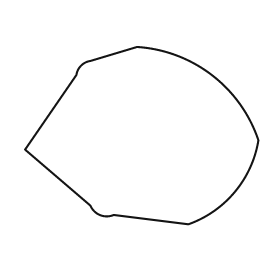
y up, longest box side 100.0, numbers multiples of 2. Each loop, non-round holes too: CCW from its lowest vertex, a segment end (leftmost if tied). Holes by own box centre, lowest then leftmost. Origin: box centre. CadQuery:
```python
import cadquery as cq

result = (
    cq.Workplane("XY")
    .moveTo(20.0, -38.0)
    .threePointArc((40.0, -24.0), (50.0, -2.0))
    .threePointArc((30.0, 26.0), (-2.0, 38.0))
    .lineTo(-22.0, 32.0)
    .threePointArc((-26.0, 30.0), (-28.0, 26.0))
    .lineTo(-50.0, -6.0)
    .lineTo(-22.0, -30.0)
    .threePointArc((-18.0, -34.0), (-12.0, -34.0))
    .close()
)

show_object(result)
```